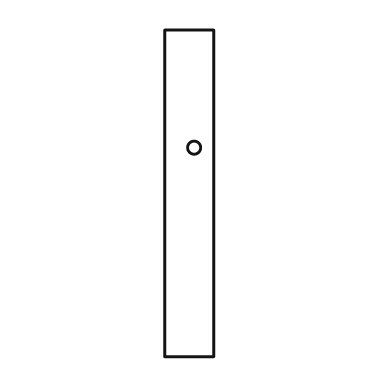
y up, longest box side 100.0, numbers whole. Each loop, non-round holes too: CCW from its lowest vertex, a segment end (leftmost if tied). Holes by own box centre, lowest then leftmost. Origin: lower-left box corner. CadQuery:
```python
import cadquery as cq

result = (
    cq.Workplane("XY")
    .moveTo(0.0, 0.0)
    .lineTo(15.0, 0.0)
    .lineTo(15.0, 100.0)
    .lineTo(0.0, 100.0)
    .close()
    .moveTo(9.0, 64.0)
    .circle(2.0)
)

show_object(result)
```